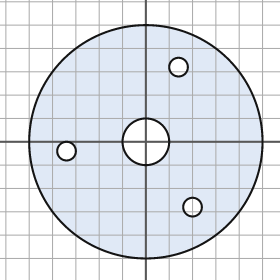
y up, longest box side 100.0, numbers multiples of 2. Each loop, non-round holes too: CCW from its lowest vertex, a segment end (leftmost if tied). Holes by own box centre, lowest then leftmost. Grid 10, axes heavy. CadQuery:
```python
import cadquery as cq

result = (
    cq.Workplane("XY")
    .moveTo(0.0, 0.0)
    .circle(50.0)
    .moveTo(20.0, -28.0)
    .circle(4.0)
    .moveTo(-34.0, -4.0)
    .circle(4.0)
    .moveTo(0.0, 0.0)
    .circle(10.0)
    .moveTo(14.0, 32.0)
    .circle(4.0)
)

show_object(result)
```